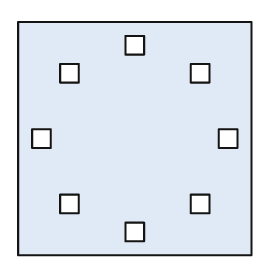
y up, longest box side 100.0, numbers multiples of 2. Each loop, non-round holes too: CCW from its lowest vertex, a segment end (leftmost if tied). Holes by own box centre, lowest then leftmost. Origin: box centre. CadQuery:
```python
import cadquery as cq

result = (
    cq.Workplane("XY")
    .moveTo(-50.0, -50.0)
    .lineTo(50.0, -50.0)
    .lineTo(50.0, 50.0)
    .lineTo(-50.0, 50.0)
    .close()
    .moveTo(-4.0, -44.0)
    .lineTo(4.0, -44.0)
    .lineTo(4.0, -36.0)
    .lineTo(-4.0, -36.0)
    .close()
    .moveTo(-32.0, -32.0)
    .lineTo(-24.0, -32.0)
    .lineTo(-24.0, -24.0)
    .lineTo(-32.0, -24.0)
    .close()
    .moveTo(24.0, -32.0)
    .lineTo(32.0, -32.0)
    .lineTo(32.0, -24.0)
    .lineTo(24.0, -24.0)
    .close()
    .moveTo(-44.0, -4.0)
    .lineTo(-36.0, -4.0)
    .lineTo(-36.0, 4.0)
    .lineTo(-44.0, 4.0)
    .close()
    .moveTo(36.0, -4.0)
    .lineTo(44.0, -4.0)
    .lineTo(44.0, 4.0)
    .lineTo(36.0, 4.0)
    .close()
    .moveTo(-32.0, 24.0)
    .lineTo(-24.0, 24.0)
    .lineTo(-24.0, 32.0)
    .lineTo(-32.0, 32.0)
    .close()
    .moveTo(24.0, 24.0)
    .lineTo(32.0, 24.0)
    .lineTo(32.0, 32.0)
    .lineTo(24.0, 32.0)
    .close()
    .moveTo(-4.0, 36.0)
    .lineTo(4.0, 36.0)
    .lineTo(4.0, 44.0)
    .lineTo(-4.0, 44.0)
    .close()
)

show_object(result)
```